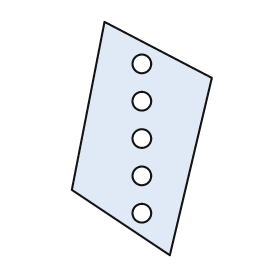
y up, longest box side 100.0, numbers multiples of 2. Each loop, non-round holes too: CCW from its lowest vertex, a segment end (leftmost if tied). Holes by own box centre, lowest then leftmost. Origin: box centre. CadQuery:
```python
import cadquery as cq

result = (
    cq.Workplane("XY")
    .moveTo(12.0, -50.0)
    .lineTo(30.0, 26.0)
    .lineTo(-16.0, 50.0)
    .lineTo(-30.0, -22.0)
    .close()
    .moveTo(0.0, -32.0)
    .circle(4.0)
    .moveTo(0.0, -16.0)
    .circle(4.0)
    .moveTo(0.0, 0.0)
    .circle(4.0)
    .moveTo(0.0, 16.0)
    .circle(4.0)
    .moveTo(0.0, 32.0)
    .circle(4.0)
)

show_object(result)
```